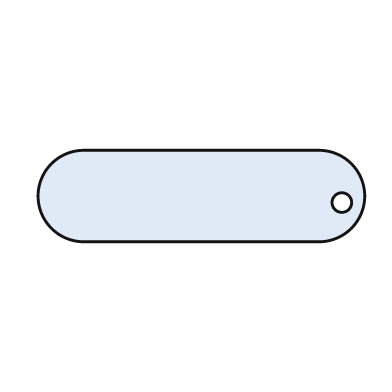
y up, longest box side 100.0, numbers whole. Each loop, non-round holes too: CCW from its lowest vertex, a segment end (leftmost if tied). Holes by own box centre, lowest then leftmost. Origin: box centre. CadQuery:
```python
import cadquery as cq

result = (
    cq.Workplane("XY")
    .moveTo(-36.0, -14.0)
    .lineTo(36.0, -14.0)
    .threePointArc((50.0, 0.0), (36.0, 14.0))
    .lineTo(-36.0, 14.0)
    .threePointArc((-50.0, 0.0), (-36.0, -14.0))
    .close()
    .moveTo(43.0, -2.0)
    .circle(3.0)
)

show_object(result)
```